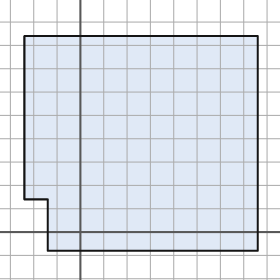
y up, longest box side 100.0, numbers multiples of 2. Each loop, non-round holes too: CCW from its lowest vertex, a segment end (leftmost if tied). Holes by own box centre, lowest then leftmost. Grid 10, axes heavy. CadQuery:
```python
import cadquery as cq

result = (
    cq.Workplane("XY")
    .moveTo(-14.0, -8.0)
    .lineTo(76.0, -8.0)
    .lineTo(76.0, 84.0)
    .lineTo(-24.0, 84.0)
    .lineTo(-24.0, 14.0)
    .lineTo(-14.0, 14.0)
    .close()
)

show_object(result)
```